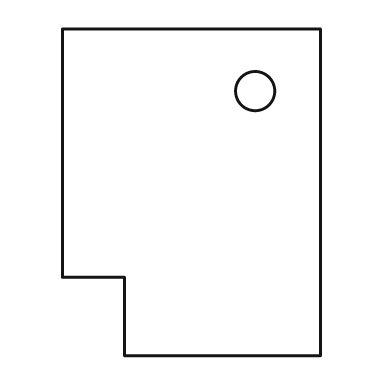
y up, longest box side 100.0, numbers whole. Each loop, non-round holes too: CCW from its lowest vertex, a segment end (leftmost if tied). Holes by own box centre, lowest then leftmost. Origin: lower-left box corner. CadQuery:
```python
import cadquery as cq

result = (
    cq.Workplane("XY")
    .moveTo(19.0, 0.0)
    .lineTo(79.0, 0.0)
    .lineTo(79.0, 100.0)
    .lineTo(0.0, 100.0)
    .lineTo(0.0, 24.0)
    .lineTo(19.0, 24.0)
    .close()
    .moveTo(59.0, 81.0)
    .circle(6.0)
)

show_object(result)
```